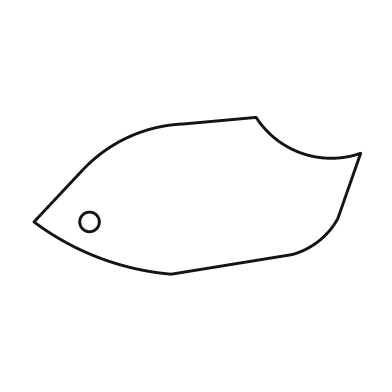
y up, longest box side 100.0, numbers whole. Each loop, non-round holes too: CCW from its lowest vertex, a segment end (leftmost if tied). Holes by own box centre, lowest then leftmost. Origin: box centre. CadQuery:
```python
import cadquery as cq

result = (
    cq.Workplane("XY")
    .moveTo(-8.0, -24.0)
    .lineTo(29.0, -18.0)
    .threePointArc((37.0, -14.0), (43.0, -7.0))
    .lineTo(50.0, 13.0)
    .threePointArc((32.0, 13.0), (18.0, 24.0))
    .lineTo(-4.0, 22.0)
    .threePointArc((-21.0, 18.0), (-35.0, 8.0))
    .lineTo(-50.0, -8.0)
    .threePointArc((-30.0, -19.0), (-8.0, -24.0))
    .close()
    .moveTo(-33.0, -8.0)
    .circle(3.0)
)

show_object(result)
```